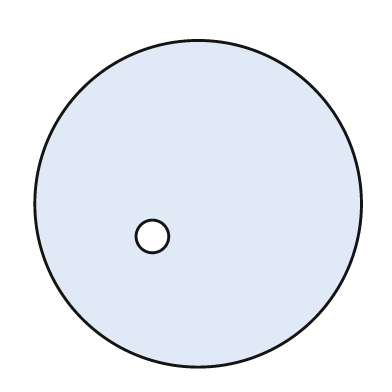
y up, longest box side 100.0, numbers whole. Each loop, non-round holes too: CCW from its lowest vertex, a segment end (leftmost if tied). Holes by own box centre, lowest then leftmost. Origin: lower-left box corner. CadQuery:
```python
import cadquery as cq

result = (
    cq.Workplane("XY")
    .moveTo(50.0, 50.0)
    .circle(50.0)
    .moveTo(36.0, 40.0)
    .circle(5.0)
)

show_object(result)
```